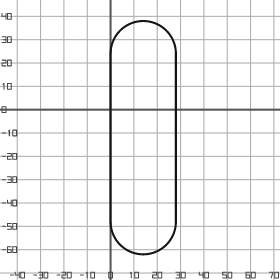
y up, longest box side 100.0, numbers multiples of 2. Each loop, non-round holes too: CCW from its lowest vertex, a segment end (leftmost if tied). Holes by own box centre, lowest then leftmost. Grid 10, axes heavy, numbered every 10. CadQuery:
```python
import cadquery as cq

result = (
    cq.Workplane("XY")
    .moveTo(0.0, -48.0)
    .threePointArc((14.0, -62.0), (28.0, -48.0))
    .lineTo(28.0, 24.0)
    .threePointArc((14.0, 38.0), (0.0, 24.0))
    .close()
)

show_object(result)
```